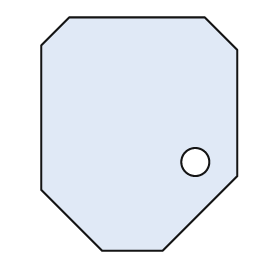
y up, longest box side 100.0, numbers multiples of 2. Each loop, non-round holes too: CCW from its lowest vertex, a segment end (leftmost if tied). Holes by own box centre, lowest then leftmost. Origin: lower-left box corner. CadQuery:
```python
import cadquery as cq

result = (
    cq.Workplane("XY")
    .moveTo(26.0, 0.0)
    .lineTo(52.0, 0.0)
    .lineTo(84.0, 32.0)
    .lineTo(84.0, 86.0)
    .lineTo(70.0, 100.0)
    .lineTo(12.0, 100.0)
    .lineTo(0.0, 88.0)
    .lineTo(0.0, 26.0)
    .close()
    .moveTo(66.0, 38.0)
    .circle(6.0)
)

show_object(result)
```